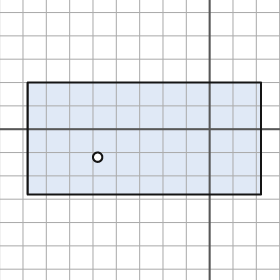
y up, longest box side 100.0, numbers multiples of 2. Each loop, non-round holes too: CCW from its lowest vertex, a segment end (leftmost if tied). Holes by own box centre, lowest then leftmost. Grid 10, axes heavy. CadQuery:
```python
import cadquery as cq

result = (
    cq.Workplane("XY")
    .moveTo(-78.0, -28.0)
    .lineTo(22.0, -28.0)
    .lineTo(22.0, 20.0)
    .lineTo(-78.0, 20.0)
    .close()
    .moveTo(-48.0, -12.0)
    .circle(2.0)
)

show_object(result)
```